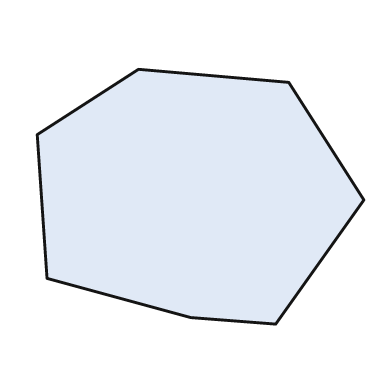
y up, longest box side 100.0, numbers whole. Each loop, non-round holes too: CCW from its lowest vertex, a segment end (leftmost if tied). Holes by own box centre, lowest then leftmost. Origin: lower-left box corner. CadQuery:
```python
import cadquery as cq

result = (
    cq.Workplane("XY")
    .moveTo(73.0, 0.0)
    .lineTo(100.0, 38.0)
    .lineTo(77.0, 74.0)
    .lineTo(31.0, 78.0)
    .lineTo(0.0, 58.0)
    .lineTo(3.0, 14.0)
    .lineTo(47.0, 2.0)
    .close()
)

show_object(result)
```